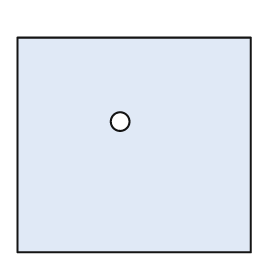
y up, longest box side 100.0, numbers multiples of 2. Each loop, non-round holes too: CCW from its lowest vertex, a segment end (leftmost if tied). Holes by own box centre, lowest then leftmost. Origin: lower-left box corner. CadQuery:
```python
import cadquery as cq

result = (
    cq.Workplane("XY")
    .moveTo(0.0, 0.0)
    .lineTo(100.0, 0.0)
    .lineTo(100.0, 92.0)
    .lineTo(0.0, 92.0)
    .close()
    .moveTo(44.0, 56.0)
    .circle(4.0)
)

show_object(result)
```